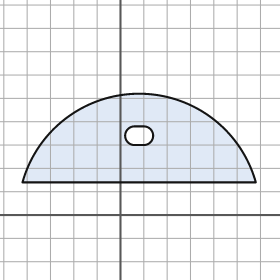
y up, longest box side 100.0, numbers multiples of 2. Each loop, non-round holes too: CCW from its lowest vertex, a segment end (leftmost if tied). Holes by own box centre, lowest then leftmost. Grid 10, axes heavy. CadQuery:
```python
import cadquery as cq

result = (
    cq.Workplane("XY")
    .moveTo(-42.0, 14.0)
    .lineTo(58.0, 14.0)
    .threePointArc((8.0, 52.0), (-42.0, 14.0))
    .close()
    .moveTo(6.0, 30.0)
    .lineTo(10.0, 30.0)
    .threePointArc((14.0, 34.0), (10.0, 38.0))
    .lineTo(6.0, 38.0)
    .threePointArc((2.0, 34.0), (6.0, 30.0))
    .close()
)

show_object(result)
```